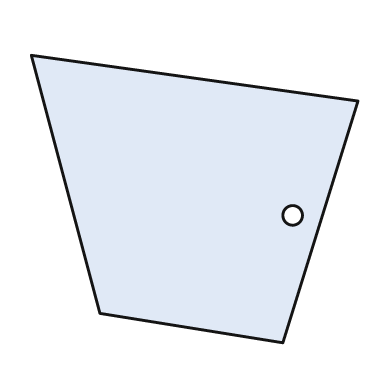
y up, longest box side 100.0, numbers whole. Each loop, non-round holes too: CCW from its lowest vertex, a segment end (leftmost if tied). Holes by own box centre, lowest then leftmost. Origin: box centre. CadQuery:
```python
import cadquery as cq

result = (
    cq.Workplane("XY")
    .moveTo(27.0, -44.0)
    .lineTo(50.0, 30.0)
    .lineTo(-50.0, 44.0)
    .lineTo(-29.0, -35.0)
    .close()
    .moveTo(30.0, -5.0)
    .circle(3.0)
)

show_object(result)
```